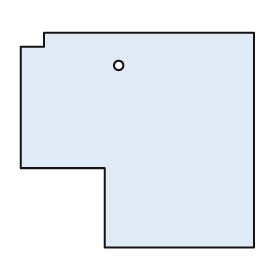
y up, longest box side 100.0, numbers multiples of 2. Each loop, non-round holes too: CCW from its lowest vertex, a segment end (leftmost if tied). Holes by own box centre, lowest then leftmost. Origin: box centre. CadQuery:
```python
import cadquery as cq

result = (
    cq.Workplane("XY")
    .moveTo(-14.0, -46.0)
    .lineTo(50.0, -46.0)
    .lineTo(50.0, 46.0)
    .lineTo(-40.0, 46.0)
    .lineTo(-40.0, 40.0)
    .lineTo(-50.0, 40.0)
    .lineTo(-50.0, -12.0)
    .lineTo(-14.0, -12.0)
    .close()
    .moveTo(-8.0, 32.0)
    .circle(2.0)
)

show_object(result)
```